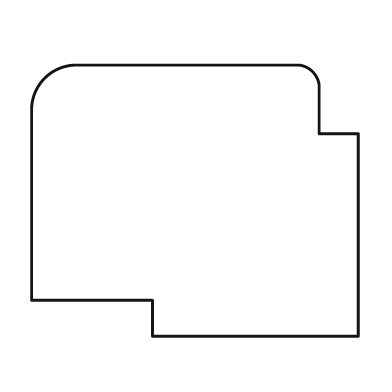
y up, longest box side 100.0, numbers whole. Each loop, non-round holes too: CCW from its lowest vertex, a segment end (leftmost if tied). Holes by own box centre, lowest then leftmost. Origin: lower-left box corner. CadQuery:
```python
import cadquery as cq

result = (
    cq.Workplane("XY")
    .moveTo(37.0, 0.0)
    .lineTo(100.0, 0.0)
    .lineTo(100.0, 62.0)
    .lineTo(88.0, 62.0)
    .lineTo(88.0, 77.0)
    .threePointArc((86.0, 81.0), (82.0, 83.0))
    .lineTo(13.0, 83.0)
    .threePointArc((4.0, 79.0), (0.0, 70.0))
    .lineTo(0.0, 11.0)
    .lineTo(37.0, 11.0)
    .close()
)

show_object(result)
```